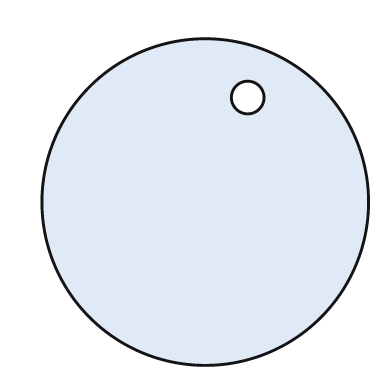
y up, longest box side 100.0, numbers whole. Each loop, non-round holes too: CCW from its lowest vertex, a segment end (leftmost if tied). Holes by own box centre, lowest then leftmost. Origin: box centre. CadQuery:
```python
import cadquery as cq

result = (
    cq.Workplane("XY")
    .moveTo(0.0, 0.0)
    .circle(50.0)
    .moveTo(13.0, 32.0)
    .circle(5.0)
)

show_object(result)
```